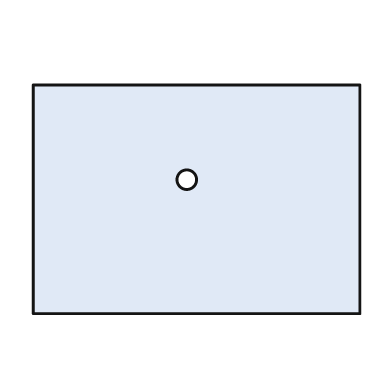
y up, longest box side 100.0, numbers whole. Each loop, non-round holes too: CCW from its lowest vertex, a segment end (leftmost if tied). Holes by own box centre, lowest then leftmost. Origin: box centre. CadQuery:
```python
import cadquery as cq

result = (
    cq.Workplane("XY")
    .moveTo(-50.0, -35.0)
    .lineTo(50.0, -35.0)
    .lineTo(50.0, 35.0)
    .lineTo(-50.0, 35.0)
    .close()
    .moveTo(-3.0, 6.0)
    .circle(3.0)
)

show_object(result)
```